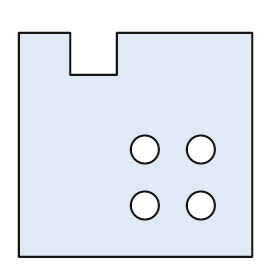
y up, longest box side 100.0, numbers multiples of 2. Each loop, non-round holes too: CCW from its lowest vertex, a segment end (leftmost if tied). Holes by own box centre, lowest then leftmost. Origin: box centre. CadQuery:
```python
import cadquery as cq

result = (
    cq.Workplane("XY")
    .moveTo(-50.0, -48.0)
    .lineTo(50.0, -48.0)
    .lineTo(50.0, 48.0)
    .lineTo(-8.0, 48.0)
    .lineTo(-8.0, 30.0)
    .lineTo(-28.0, 30.0)
    .lineTo(-28.0, 48.0)
    .lineTo(-50.0, 48.0)
    .close()
    .moveTo(4.0, -26.0)
    .circle(6.0)
    .moveTo(28.0, -26.0)
    .circle(6.0)
    .moveTo(4.0, -2.0)
    .circle(6.0)
    .moveTo(28.0, -2.0)
    .circle(6.0)
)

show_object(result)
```